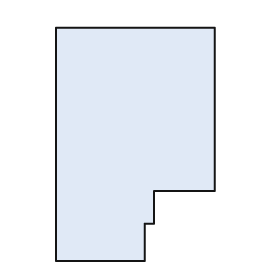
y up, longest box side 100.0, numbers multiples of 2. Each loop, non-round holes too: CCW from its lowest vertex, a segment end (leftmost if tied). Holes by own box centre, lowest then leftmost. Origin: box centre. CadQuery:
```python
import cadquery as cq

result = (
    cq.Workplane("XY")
    .moveTo(-34.0, -50.0)
    .lineTo(4.0, -50.0)
    .lineTo(4.0, -34.0)
    .lineTo(8.0, -34.0)
    .lineTo(8.0, -20.0)
    .lineTo(34.0, -20.0)
    .lineTo(34.0, 50.0)
    .lineTo(-34.0, 50.0)
    .close()
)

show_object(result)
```